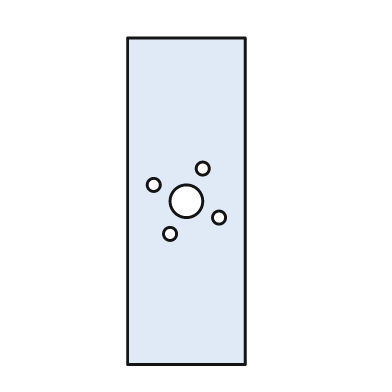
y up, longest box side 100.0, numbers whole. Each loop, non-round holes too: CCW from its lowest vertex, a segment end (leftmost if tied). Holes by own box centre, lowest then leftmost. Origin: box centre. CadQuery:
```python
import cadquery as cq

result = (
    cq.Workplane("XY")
    .moveTo(-18.0, -50.0)
    .lineTo(18.0, -50.0)
    .lineTo(18.0, 50.0)
    .lineTo(-18.0, 50.0)
    .close()
    .moveTo(-5.0, -10.0)
    .circle(2.0)
    .moveTo(10.0, -5.0)
    .circle(2.0)
    .moveTo(0.0, 0.0)
    .circle(5.0)
    .moveTo(-10.0, 5.0)
    .circle(2.0)
    .moveTo(5.0, 10.0)
    .circle(2.0)
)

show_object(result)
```